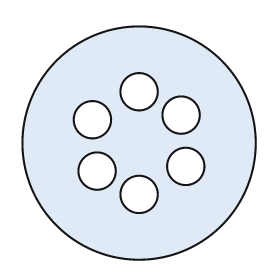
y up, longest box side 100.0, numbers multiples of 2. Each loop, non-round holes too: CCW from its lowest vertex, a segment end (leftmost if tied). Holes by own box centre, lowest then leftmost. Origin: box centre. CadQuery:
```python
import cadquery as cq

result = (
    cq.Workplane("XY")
    .moveTo(0.0, 0.0)
    .circle(50.0)
    .moveTo(0.0, -22.0)
    .circle(8.0)
    .moveTo(-18.0, -12.0)
    .circle(8.0)
    .moveTo(20.0, -10.0)
    .circle(8.0)
    .moveTo(-20.0, 10.0)
    .circle(8.0)
    .moveTo(18.0, 12.0)
    .circle(8.0)
    .moveTo(0.0, 22.0)
    .circle(8.0)
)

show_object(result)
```